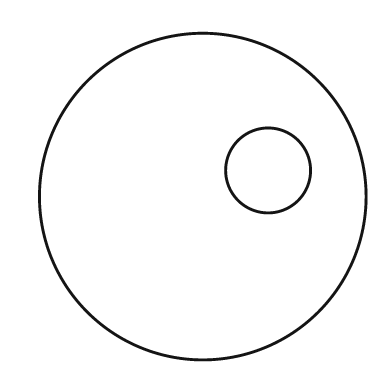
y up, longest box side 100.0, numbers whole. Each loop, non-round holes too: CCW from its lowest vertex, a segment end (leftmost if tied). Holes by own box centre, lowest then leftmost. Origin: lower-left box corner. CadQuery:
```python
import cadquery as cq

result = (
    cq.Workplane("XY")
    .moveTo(50.0, 50.0)
    .circle(50.0)
    .moveTo(70.0, 58.0)
    .circle(13.0)
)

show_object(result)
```